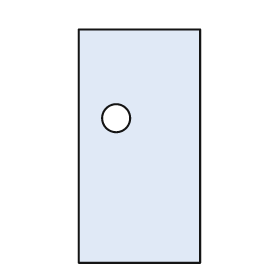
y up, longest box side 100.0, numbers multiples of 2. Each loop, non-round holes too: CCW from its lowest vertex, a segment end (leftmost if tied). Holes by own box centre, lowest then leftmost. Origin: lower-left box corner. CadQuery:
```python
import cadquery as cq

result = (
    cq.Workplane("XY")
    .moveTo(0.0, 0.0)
    .lineTo(52.0, 0.0)
    .lineTo(52.0, 100.0)
    .lineTo(0.0, 100.0)
    .close()
    .moveTo(16.0, 62.0)
    .circle(6.0)
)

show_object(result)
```